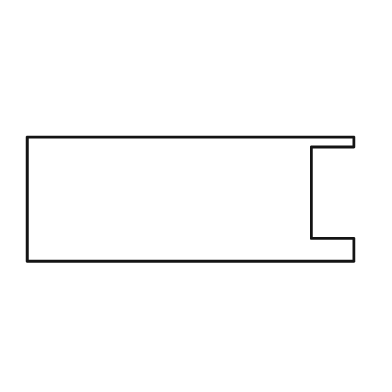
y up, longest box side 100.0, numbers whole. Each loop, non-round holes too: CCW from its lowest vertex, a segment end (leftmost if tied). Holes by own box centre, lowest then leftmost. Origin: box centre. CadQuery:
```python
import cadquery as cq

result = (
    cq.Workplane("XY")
    .moveTo(-50.0, -19.0)
    .lineTo(50.0, -19.0)
    .lineTo(50.0, -12.0)
    .lineTo(37.0, -12.0)
    .lineTo(37.0, 16.0)
    .lineTo(50.0, 16.0)
    .lineTo(50.0, 19.0)
    .lineTo(-50.0, 19.0)
    .close()
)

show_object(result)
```